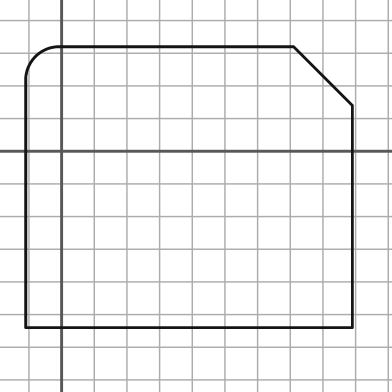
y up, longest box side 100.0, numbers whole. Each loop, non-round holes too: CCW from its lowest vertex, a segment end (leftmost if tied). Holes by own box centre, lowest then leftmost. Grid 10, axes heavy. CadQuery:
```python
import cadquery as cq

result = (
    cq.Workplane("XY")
    .moveTo(-11.0, -54.0)
    .lineTo(89.0, -54.0)
    .lineTo(89.0, 14.0)
    .lineTo(71.0, 32.0)
    .lineTo(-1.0, 32.0)
    .threePointArc((-8.0, 29.0), (-11.0, 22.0))
    .close()
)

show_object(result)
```